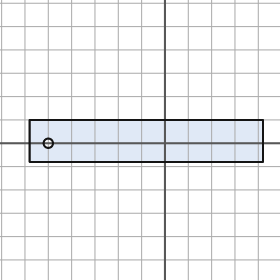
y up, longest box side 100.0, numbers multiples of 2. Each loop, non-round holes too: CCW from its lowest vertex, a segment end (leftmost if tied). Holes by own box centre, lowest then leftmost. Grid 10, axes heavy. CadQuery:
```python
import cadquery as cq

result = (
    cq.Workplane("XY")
    .moveTo(-58.0, -8.0)
    .lineTo(42.0, -8.0)
    .lineTo(42.0, 10.0)
    .lineTo(-58.0, 10.0)
    .close()
    .moveTo(-50.0, 0.0)
    .circle(2.0)
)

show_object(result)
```